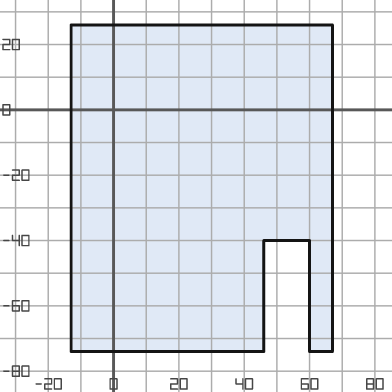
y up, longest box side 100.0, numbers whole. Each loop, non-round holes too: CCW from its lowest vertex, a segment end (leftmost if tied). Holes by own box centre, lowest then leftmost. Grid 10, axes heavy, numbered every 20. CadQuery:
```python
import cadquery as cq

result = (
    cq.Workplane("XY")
    .moveTo(-13.0, -74.0)
    .lineTo(46.0, -74.0)
    .lineTo(46.0, -40.0)
    .lineTo(60.0, -40.0)
    .lineTo(60.0, -74.0)
    .lineTo(67.0, -74.0)
    .lineTo(67.0, 26.0)
    .lineTo(-13.0, 26.0)
    .close()
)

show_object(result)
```